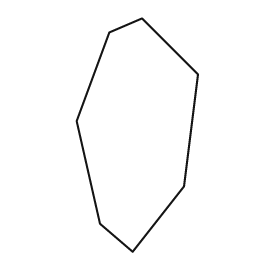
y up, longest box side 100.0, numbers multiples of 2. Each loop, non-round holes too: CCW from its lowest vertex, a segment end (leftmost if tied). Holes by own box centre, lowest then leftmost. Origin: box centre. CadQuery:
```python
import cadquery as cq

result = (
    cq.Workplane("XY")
    .moveTo(-2.0, -50.0)
    .lineTo(20.0, -22.0)
    .lineTo(26.0, 26.0)
    .lineTo(2.0, 50.0)
    .lineTo(-12.0, 44.0)
    .lineTo(-26.0, 6.0)
    .lineTo(-16.0, -38.0)
    .close()
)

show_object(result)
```